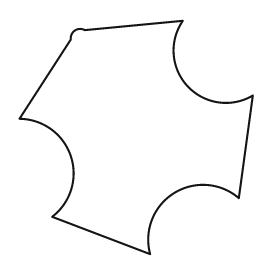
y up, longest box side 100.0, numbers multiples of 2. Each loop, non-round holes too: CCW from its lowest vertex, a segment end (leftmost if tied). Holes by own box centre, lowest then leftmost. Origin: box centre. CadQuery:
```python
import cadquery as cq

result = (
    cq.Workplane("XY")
    .moveTo(6.0, -50.0)
    .threePointArc((16.0, -24.0), (44.0, -26.0))
    .lineTo(50.0, 18.0)
    .threePointArc((22.0, 22.0), (20.0, 50.0))
    .lineTo(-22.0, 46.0)
    .threePointArc((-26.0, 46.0), (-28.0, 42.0))
    .lineTo(-50.0, 8.0)
    .threePointArc((-28.0, -8.0), (-36.0, -34.0))
    .close()
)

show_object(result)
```